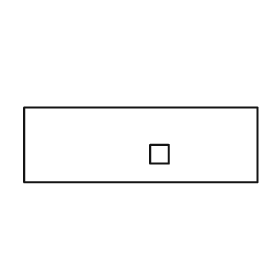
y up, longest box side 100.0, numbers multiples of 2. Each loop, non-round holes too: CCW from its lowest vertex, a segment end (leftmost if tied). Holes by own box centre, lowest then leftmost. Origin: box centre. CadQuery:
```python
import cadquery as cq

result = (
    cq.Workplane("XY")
    .moveTo(-50.0, -16.0)
    .lineTo(50.0, -16.0)
    .lineTo(50.0, 16.0)
    .lineTo(-50.0, 16.0)
    .close()
    .moveTo(4.0, -8.0)
    .lineTo(12.0, -8.0)
    .lineTo(12.0, 0.0)
    .lineTo(4.0, 0.0)
    .close()
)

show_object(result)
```